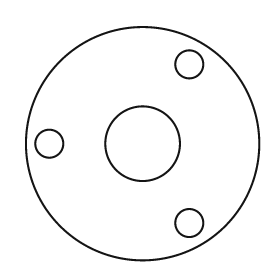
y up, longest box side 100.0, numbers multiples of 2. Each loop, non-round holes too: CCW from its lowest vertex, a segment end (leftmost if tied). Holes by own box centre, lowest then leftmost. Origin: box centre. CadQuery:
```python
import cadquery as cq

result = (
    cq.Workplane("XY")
    .moveTo(0.0, 0.0)
    .circle(50.0)
    .moveTo(20.0, -34.0)
    .circle(6.0)
    .moveTo(-40.0, 0.0)
    .circle(6.0)
    .moveTo(0.0, 0.0)
    .circle(16.0)
    .moveTo(20.0, 34.0)
    .circle(6.0)
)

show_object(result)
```